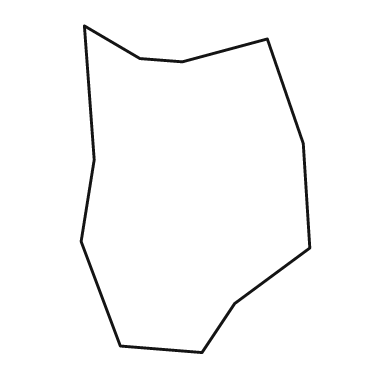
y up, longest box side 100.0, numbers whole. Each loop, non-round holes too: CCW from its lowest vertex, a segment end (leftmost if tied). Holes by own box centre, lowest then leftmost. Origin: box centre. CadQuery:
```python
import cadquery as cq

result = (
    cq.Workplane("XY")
    .moveTo(2.0, -50.0)
    .lineTo(12.0, -35.0)
    .lineTo(35.0, -18.0)
    .lineTo(33.0, 14.0)
    .lineTo(22.0, 46.0)
    .lineTo(-4.0, 39.0)
    .lineTo(-17.0, 40.0)
    .lineTo(-34.0, 50.0)
    .lineTo(-31.0, 9.0)
    .lineTo(-35.0, -16.0)
    .lineTo(-23.0, -48.0)
    .close()
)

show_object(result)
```